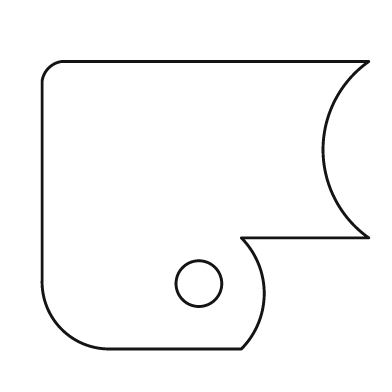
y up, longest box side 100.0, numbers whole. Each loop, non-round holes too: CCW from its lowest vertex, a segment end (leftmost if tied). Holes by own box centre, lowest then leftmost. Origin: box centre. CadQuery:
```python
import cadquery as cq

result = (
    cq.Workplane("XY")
    .moveTo(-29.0, -44.0)
    .lineTo(11.0, -44.0)
    .threePointArc((18.0, -27.0), (11.0, -10.0))
    .lineTo(50.0, -10.0)
    .threePointArc((36.0, 17.0), (50.0, 44.0))
    .lineTo(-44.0, 44.0)
    .threePointArc((-48.0, 42.0), (-50.0, 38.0))
    .lineTo(-50.0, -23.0)
    .threePointArc((-44.0, -38.0), (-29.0, -44.0))
    .close()
    .moveTo(-2.0, -24.0)
    .circle(7.0)
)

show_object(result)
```